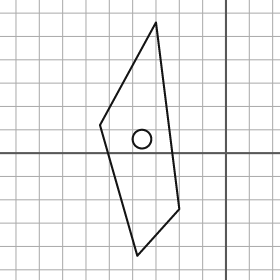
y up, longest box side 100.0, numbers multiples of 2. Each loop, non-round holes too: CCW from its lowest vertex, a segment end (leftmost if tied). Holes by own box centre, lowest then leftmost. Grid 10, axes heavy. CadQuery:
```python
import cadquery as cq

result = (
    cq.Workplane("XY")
    .moveTo(-38.0, -44.0)
    .lineTo(-20.0, -24.0)
    .lineTo(-30.0, 56.0)
    .lineTo(-54.0, 12.0)
    .close()
    .moveTo(-36.0, 6.0)
    .circle(4.0)
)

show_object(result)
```